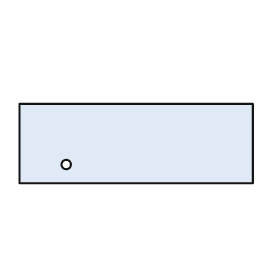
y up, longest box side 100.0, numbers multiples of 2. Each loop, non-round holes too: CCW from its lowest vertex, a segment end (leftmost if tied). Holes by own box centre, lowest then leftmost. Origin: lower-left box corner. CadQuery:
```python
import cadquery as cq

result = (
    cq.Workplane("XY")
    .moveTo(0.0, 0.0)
    .lineTo(100.0, 0.0)
    .lineTo(100.0, 34.0)
    .lineTo(0.0, 34.0)
    .close()
    .moveTo(20.0, 8.0)
    .circle(2.0)
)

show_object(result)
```